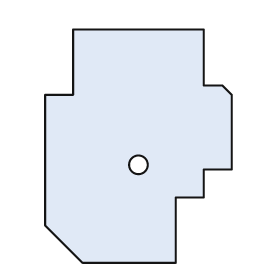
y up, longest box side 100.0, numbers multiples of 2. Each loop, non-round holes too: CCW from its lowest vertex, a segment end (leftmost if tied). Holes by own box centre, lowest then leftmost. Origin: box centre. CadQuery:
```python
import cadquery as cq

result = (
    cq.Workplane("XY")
    .moveTo(-24.0, -50.0)
    .lineTo(16.0, -50.0)
    .lineTo(16.0, -22.0)
    .lineTo(28.0, -22.0)
    .lineTo(28.0, -10.0)
    .lineTo(40.0, -10.0)
    .lineTo(40.0, 22.0)
    .lineTo(36.0, 26.0)
    .lineTo(28.0, 26.0)
    .lineTo(28.0, 50.0)
    .lineTo(-28.0, 50.0)
    .lineTo(-28.0, 22.0)
    .lineTo(-40.0, 22.0)
    .lineTo(-40.0, -34.0)
    .close()
    .moveTo(0.0, -8.0)
    .circle(4.0)
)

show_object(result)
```